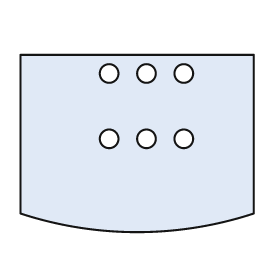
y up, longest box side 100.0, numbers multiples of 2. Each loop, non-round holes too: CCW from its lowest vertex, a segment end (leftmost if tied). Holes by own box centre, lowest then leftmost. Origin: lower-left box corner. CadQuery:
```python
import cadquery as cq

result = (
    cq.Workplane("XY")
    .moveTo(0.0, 8.0)
    .threePointArc((50.0, 0.0), (100.0, 8.0))
    .lineTo(100.0, 76.0)
    .lineTo(0.0, 76.0)
    .close()
    .moveTo(38.0, 40.0)
    .circle(4.0)
    .moveTo(54.0, 40.0)
    .circle(4.0)
    .moveTo(70.0, 40.0)
    .circle(4.0)
    .moveTo(38.0, 68.0)
    .circle(4.0)
    .moveTo(54.0, 68.0)
    .circle(4.0)
    .moveTo(70.0, 68.0)
    .circle(4.0)
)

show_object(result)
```